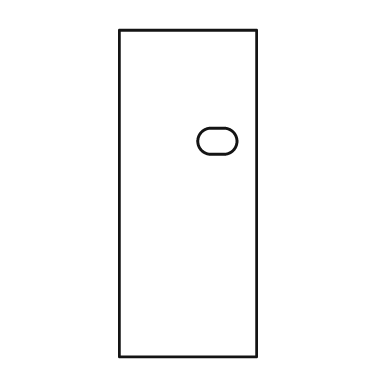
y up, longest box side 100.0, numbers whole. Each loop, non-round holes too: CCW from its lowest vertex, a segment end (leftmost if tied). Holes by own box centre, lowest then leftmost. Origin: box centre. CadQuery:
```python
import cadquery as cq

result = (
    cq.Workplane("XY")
    .moveTo(-21.0, -50.0)
    .lineTo(21.0, -50.0)
    .lineTo(21.0, 50.0)
    .lineTo(-21.0, 50.0)
    .close()
    .moveTo(7.0, 12.0)
    .lineTo(11.0, 12.0)
    .threePointArc((15.0, 16.0), (11.0, 20.0))
    .lineTo(7.0, 20.0)
    .threePointArc((3.0, 16.0), (7.0, 12.0))
    .close()
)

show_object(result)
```